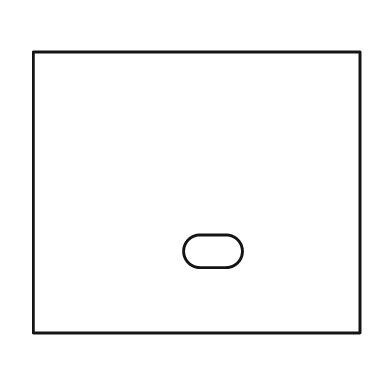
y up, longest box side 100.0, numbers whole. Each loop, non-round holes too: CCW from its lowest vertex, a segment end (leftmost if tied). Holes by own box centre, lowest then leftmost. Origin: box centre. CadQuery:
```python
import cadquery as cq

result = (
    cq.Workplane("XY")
    .moveTo(-50.0, -43.0)
    .lineTo(50.0, -43.0)
    .lineTo(50.0, 43.0)
    .lineTo(-50.0, 43.0)
    .close()
    .moveTo(1.0, -23.0)
    .lineTo(9.0, -23.0)
    .threePointArc((14.0, -18.0), (9.0, -13.0))
    .lineTo(1.0, -13.0)
    .threePointArc((-4.0, -18.0), (1.0, -23.0))
    .close()
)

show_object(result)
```